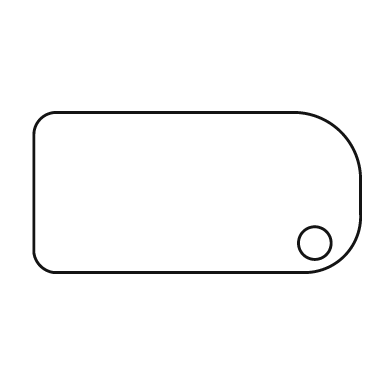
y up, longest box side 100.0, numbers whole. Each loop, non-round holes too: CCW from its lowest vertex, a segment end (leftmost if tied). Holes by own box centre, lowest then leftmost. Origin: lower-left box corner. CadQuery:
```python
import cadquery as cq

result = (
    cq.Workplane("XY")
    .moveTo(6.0, 0.0)
    .lineTo(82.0, 0.0)
    .threePointArc((95.0, 5.0), (100.0, 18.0))
    .lineTo(100.0, 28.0)
    .threePointArc((94.0, 43.0), (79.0, 49.0))
    .lineTo(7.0, 49.0)
    .threePointArc((2.0, 47.0), (0.0, 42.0))
    .lineTo(0.0, 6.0)
    .threePointArc((2.0, 2.0), (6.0, 0.0))
    .close()
    .moveTo(86.0, 9.0)
    .circle(5.0)
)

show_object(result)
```